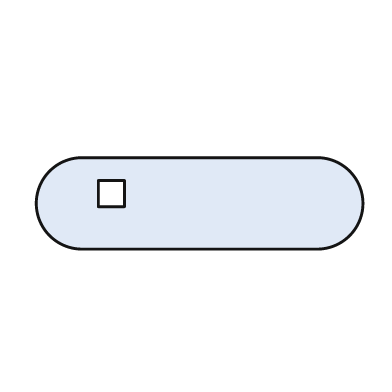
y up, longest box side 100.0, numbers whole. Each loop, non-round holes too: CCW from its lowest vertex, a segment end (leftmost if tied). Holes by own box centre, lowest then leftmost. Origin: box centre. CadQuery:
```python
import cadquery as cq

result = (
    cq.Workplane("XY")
    .moveTo(-36.0, -14.0)
    .lineTo(36.0, -14.0)
    .threePointArc((50.0, 0.0), (36.0, 14.0))
    .lineTo(-36.0, 14.0)
    .threePointArc((-50.0, 0.0), (-36.0, -14.0))
    .close()
    .moveTo(-31.0, -1.0)
    .lineTo(-23.0, -1.0)
    .lineTo(-23.0, 7.0)
    .lineTo(-31.0, 7.0)
    .close()
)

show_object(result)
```